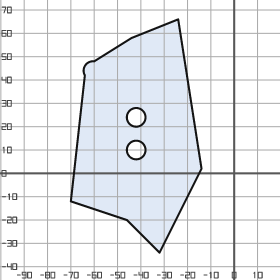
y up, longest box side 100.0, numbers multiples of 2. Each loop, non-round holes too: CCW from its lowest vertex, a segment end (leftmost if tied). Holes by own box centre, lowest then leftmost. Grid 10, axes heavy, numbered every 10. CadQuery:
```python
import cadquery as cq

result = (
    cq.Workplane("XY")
    .moveTo(-32.0, -34.0)
    .lineTo(-14.0, 2.0)
    .lineTo(-24.0, 66.0)
    .lineTo(-44.0, 58.0)
    .lineTo(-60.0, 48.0)
    .threePointArc((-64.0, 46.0), (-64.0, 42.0))
    .lineTo(-70.0, -12.0)
    .lineTo(-46.0, -20.0)
    .close()
    .moveTo(-42.0, 10.0)
    .circle(4.0)
    .moveTo(-42.0, 24.0)
    .circle(4.0)
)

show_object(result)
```